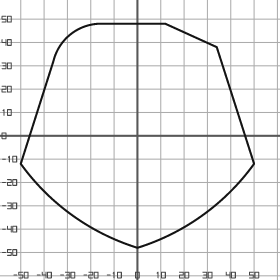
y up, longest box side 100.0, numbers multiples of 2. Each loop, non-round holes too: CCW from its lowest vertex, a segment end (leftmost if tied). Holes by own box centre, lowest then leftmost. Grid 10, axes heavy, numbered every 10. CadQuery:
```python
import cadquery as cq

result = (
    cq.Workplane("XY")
    .moveTo(0.0, -48.0)
    .threePointArc((28.0, -34.0), (50.0, -12.0))
    .lineTo(34.0, 38.0)
    .lineTo(12.0, 48.0)
    .lineTo(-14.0, 48.0)
    .threePointArc((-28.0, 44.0), (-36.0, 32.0))
    .lineTo(-50.0, -12.0)
    .threePointArc((-28.0, -34.0), (0.0, -48.0))
    .close()
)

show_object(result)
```